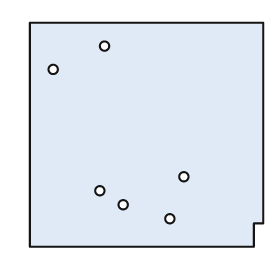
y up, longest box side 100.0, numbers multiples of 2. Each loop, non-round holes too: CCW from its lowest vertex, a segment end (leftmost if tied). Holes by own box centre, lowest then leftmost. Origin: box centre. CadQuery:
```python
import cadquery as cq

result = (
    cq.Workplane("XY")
    .moveTo(-50.0, -48.0)
    .lineTo(46.0, -48.0)
    .lineTo(46.0, -38.0)
    .lineTo(50.0, -38.0)
    .lineTo(50.0, 48.0)
    .lineTo(-50.0, 48.0)
    .close()
    .moveTo(10.0, -36.0)
    .circle(2.0)
    .moveTo(-10.0, -30.0)
    .circle(2.0)
    .moveTo(-20.0, -24.0)
    .circle(2.0)
    .moveTo(16.0, -18.0)
    .circle(2.0)
    .moveTo(-40.0, 28.0)
    .circle(2.0)
    .moveTo(-18.0, 38.0)
    .circle(2.0)
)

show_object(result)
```